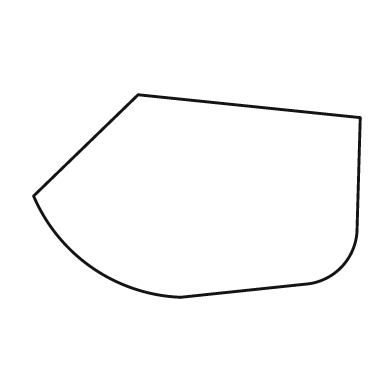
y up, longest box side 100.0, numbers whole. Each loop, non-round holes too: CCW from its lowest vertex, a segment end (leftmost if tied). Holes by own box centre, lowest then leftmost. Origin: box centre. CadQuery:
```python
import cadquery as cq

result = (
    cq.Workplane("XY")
    .moveTo(-5.0, -31.0)
    .lineTo(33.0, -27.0)
    .threePointArc((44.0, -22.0), (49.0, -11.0))
    .lineTo(50.0, 24.0)
    .lineTo(-18.0, 31.0)
    .lineTo(-50.0, 0.0)
    .threePointArc((-32.0, -22.0), (-5.0, -31.0))
    .close()
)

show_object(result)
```